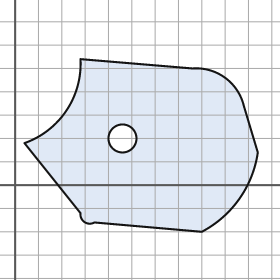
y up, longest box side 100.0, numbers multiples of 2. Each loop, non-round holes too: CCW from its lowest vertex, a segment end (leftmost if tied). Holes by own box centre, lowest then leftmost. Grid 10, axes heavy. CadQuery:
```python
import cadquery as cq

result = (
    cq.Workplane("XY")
    .moveTo(80.0, -20.0)
    .threePointArc((96.0, -6.0), (104.0, 14.0))
    .lineTo(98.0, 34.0)
    .threePointArc((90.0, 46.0), (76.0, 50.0))
    .lineTo(28.0, 54.0)
    .threePointArc((22.0, 32.0), (4.0, 18.0))
    .lineTo(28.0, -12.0)
    .threePointArc((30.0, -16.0), (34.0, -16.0))
    .close()
    .moveTo(46.0, 20.0)
    .circle(6.0)
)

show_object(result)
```